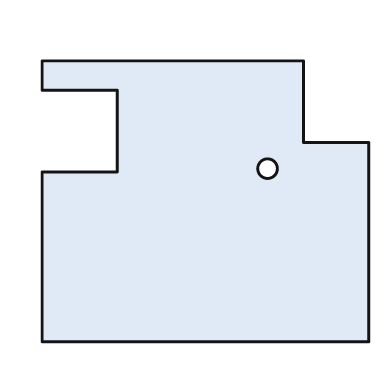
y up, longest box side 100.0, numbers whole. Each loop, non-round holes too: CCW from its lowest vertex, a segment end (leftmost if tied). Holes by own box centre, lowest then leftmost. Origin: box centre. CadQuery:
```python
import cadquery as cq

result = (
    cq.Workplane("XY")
    .moveTo(-50.0, -43.0)
    .lineTo(50.0, -43.0)
    .lineTo(50.0, 18.0)
    .lineTo(30.0, 18.0)
    .lineTo(30.0, 43.0)
    .lineTo(-50.0, 43.0)
    .lineTo(-50.0, 34.0)
    .lineTo(-27.0, 34.0)
    .lineTo(-27.0, 9.0)
    .lineTo(-50.0, 9.0)
    .close()
    .moveTo(19.0, 10.0)
    .circle(3.0)
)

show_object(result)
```